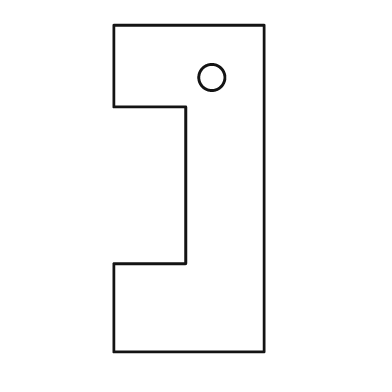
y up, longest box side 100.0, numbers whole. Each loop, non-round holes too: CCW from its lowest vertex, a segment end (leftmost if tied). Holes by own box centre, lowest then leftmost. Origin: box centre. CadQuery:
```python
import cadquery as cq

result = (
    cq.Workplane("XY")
    .moveTo(-23.0, -50.0)
    .lineTo(23.0, -50.0)
    .lineTo(23.0, 50.0)
    .lineTo(-23.0, 50.0)
    .lineTo(-23.0, 25.0)
    .lineTo(-1.0, 25.0)
    .lineTo(-1.0, -23.0)
    .lineTo(-23.0, -23.0)
    .close()
    .moveTo(7.0, 34.0)
    .circle(4.0)
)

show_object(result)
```